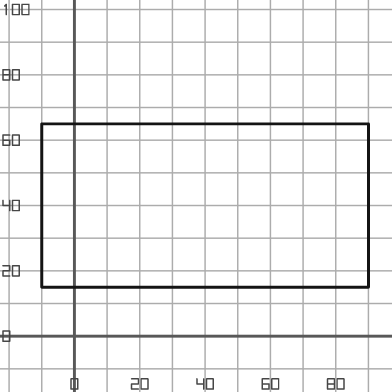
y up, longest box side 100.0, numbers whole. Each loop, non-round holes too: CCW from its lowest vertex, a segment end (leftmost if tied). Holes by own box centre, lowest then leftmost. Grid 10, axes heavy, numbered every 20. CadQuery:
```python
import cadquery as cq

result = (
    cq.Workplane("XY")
    .moveTo(-10.0, 15.0)
    .lineTo(90.0, 15.0)
    .lineTo(90.0, 65.0)
    .lineTo(-10.0, 65.0)
    .close()
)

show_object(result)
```